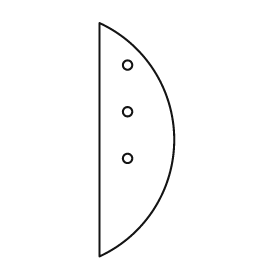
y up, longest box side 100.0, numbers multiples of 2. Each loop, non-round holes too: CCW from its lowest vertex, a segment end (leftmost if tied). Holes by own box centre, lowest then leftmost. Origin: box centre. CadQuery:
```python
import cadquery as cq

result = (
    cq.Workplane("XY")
    .moveTo(-16.0, -50.0)
    .threePointArc((16.0, 0.0), (-16.0, 50.0))
    .close()
    .moveTo(-4.0, -8.0)
    .circle(2.0)
    .moveTo(-4.0, 12.0)
    .circle(2.0)
    .moveTo(-4.0, 32.0)
    .circle(2.0)
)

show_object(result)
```